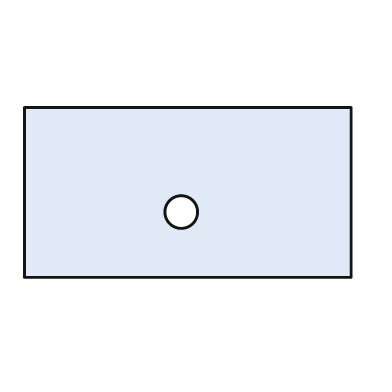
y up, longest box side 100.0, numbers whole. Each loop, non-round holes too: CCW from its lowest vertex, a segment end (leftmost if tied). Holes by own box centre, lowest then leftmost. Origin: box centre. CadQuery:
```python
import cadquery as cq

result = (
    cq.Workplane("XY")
    .moveTo(-50.0, -26.0)
    .lineTo(50.0, -26.0)
    .lineTo(50.0, 26.0)
    .lineTo(-50.0, 26.0)
    .close()
    .moveTo(-2.0, -6.0)
    .circle(5.0)
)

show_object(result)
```